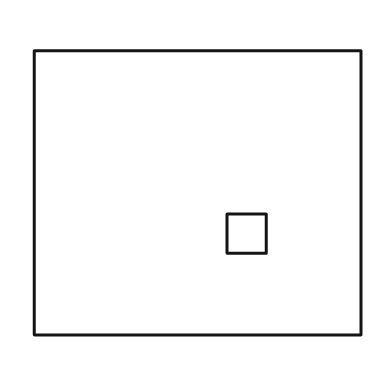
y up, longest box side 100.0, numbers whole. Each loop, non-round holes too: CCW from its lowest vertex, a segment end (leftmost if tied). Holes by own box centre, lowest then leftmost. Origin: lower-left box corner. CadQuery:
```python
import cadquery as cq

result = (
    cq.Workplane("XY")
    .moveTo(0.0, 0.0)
    .lineTo(100.0, 0.0)
    .lineTo(100.0, 87.0)
    .lineTo(0.0, 87.0)
    .close()
    .moveTo(59.0, 25.0)
    .lineTo(71.0, 25.0)
    .lineTo(71.0, 37.0)
    .lineTo(59.0, 37.0)
    .close()
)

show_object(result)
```